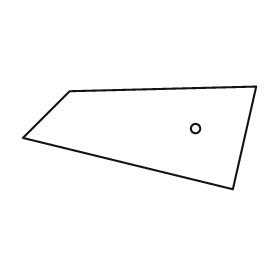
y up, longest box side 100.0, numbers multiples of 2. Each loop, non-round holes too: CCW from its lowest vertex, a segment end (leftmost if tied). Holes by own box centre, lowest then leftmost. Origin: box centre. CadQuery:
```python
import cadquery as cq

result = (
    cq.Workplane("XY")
    .moveTo(40.0, -22.0)
    .lineTo(50.0, 22.0)
    .lineTo(-30.0, 20.0)
    .lineTo(-50.0, 0.0)
    .close()
    .moveTo(24.0, 4.0)
    .circle(2.0)
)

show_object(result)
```